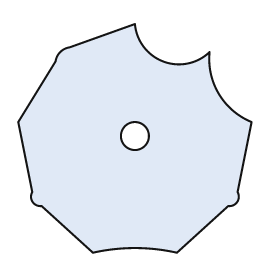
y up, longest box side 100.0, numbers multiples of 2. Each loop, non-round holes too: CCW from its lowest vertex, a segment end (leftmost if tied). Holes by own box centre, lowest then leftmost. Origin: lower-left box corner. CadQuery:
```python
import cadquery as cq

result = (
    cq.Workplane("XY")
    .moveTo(32.0, 0.0)
    .threePointArc((50.0, 2.0), (68.0, 0.0))
    .lineTo(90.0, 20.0)
    .threePointArc((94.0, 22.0), (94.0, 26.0))
    .lineTo(100.0, 56.0)
    .threePointArc((86.0, 68.0), (82.0, 86.0))
    .threePointArc((62.0, 82.0), (50.0, 98.0))
    .lineTo(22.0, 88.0)
    .threePointArc((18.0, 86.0), (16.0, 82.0))
    .lineTo(0.0, 56.0)
    .lineTo(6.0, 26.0)
    .threePointArc((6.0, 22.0), (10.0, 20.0))
    .close()
    .moveTo(50.0, 50.0)
    .circle(6.0)
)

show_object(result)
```